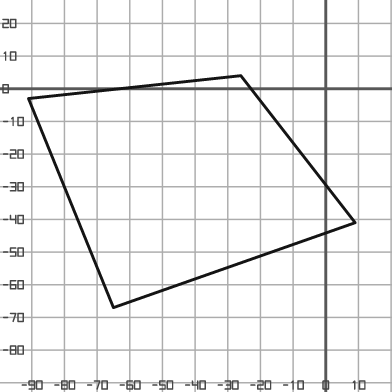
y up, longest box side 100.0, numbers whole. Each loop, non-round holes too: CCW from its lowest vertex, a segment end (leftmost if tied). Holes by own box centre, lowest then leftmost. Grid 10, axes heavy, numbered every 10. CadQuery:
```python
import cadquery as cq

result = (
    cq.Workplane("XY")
    .moveTo(-65.0, -67.0)
    .lineTo(9.0, -41.0)
    .lineTo(-26.0, 4.0)
    .lineTo(-91.0, -3.0)
    .close()
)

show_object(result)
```